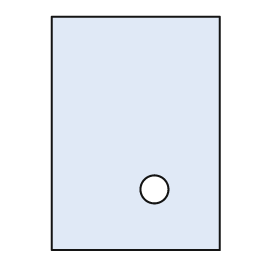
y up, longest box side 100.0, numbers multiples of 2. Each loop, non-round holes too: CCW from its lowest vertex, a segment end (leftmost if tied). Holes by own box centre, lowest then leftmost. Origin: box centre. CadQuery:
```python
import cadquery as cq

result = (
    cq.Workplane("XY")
    .moveTo(-36.0, -50.0)
    .lineTo(36.0, -50.0)
    .lineTo(36.0, 50.0)
    .lineTo(-36.0, 50.0)
    .close()
    .moveTo(8.0, -24.0)
    .circle(6.0)
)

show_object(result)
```